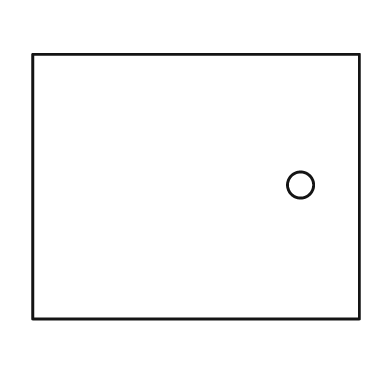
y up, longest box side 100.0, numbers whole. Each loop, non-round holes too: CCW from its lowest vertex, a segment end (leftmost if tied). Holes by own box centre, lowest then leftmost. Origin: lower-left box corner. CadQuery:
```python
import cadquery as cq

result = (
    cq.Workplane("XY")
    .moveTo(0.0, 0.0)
    .lineTo(100.0, 0.0)
    .lineTo(100.0, 81.0)
    .lineTo(0.0, 81.0)
    .close()
    .moveTo(82.0, 41.0)
    .circle(4.0)
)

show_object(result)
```